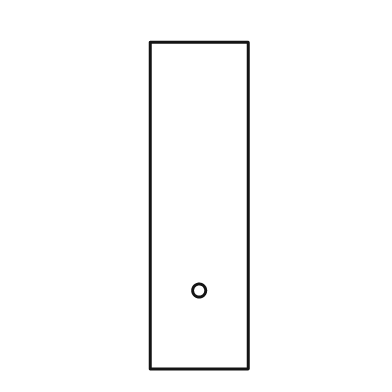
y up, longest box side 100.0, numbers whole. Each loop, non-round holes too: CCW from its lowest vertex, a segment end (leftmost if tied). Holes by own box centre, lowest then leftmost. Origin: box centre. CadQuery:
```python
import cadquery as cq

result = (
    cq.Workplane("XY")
    .moveTo(-15.0, -50.0)
    .lineTo(15.0, -50.0)
    .lineTo(15.0, 50.0)
    .lineTo(-15.0, 50.0)
    .close()
    .moveTo(0.0, -26.0)
    .circle(2.0)
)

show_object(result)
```